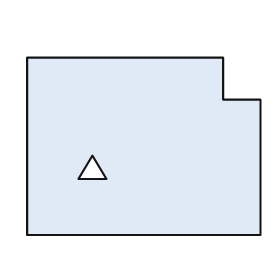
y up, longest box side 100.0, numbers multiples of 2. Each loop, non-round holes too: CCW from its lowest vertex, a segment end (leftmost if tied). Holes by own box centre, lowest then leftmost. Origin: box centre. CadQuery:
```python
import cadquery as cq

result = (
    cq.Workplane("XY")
    .moveTo(-50.0, -38.0)
    .lineTo(50.0, -38.0)
    .lineTo(50.0, 20.0)
    .lineTo(34.0, 20.0)
    .lineTo(34.0, 38.0)
    .lineTo(-50.0, 38.0)
    .close()
    .moveTo(-28.0, -14.0)
    .lineTo(-16.0, -14.0)
    .lineTo(-22.0, -4.0)
    .close()
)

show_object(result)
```